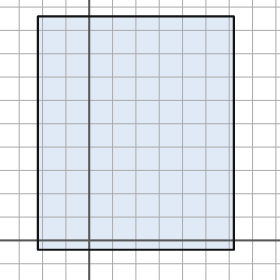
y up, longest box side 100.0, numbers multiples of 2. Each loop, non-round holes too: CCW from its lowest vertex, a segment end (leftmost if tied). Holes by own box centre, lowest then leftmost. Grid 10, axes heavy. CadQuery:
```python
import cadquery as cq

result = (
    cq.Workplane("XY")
    .moveTo(-22.0, -4.0)
    .lineTo(62.0, -4.0)
    .lineTo(62.0, 96.0)
    .lineTo(-22.0, 96.0)
    .close()
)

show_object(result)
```